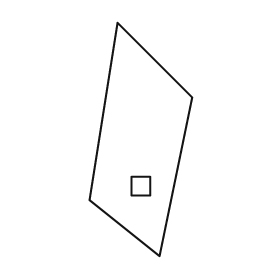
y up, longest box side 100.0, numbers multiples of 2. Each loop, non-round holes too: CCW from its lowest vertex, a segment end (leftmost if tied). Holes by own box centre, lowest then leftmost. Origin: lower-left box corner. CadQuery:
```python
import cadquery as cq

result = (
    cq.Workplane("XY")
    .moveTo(30.0, 0.0)
    .lineTo(44.0, 68.0)
    .lineTo(12.0, 100.0)
    .lineTo(0.0, 24.0)
    .close()
    .moveTo(18.0, 26.0)
    .lineTo(26.0, 26.0)
    .lineTo(26.0, 34.0)
    .lineTo(18.0, 34.0)
    .close()
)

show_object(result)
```